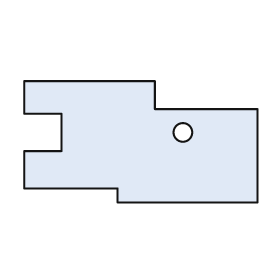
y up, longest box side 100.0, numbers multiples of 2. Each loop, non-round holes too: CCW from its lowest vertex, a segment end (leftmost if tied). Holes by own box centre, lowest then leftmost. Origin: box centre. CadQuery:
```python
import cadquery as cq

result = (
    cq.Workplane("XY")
    .moveTo(-10.0, -26.0)
    .lineTo(50.0, -26.0)
    .lineTo(50.0, 14.0)
    .lineTo(6.0, 14.0)
    .lineTo(6.0, 26.0)
    .lineTo(-50.0, 26.0)
    .lineTo(-50.0, 12.0)
    .lineTo(-34.0, 12.0)
    .lineTo(-34.0, -4.0)
    .lineTo(-50.0, -4.0)
    .lineTo(-50.0, -20.0)
    .lineTo(-10.0, -20.0)
    .close()
    .moveTo(18.0, 4.0)
    .circle(4.0)
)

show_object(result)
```